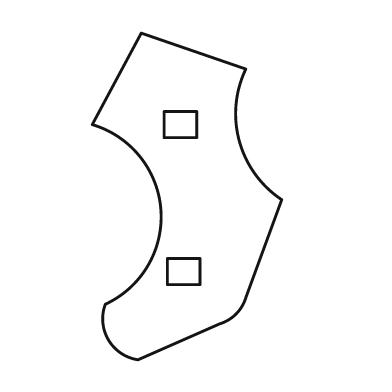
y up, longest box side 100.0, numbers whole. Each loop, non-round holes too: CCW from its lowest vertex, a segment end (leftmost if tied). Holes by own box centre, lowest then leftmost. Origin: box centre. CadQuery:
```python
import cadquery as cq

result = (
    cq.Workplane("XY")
    .moveTo(-15.0, -50.0)
    .lineTo(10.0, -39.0)
    .threePointArc((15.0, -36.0), (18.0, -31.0))
    .lineTo(29.0, -1.0)
    .threePointArc((16.0, 17.0), (18.0, 39.0))
    .lineTo(-14.0, 50.0)
    .lineTo(-29.0, 22.0)
    .threePointArc((-8.0, -4.0), (-25.0, -33.0))
    .threePointArc((-24.0, -44.0), (-15.0, -50.0))
    .close()
    .moveTo(-6.0, -27.0)
    .lineTo(4.0, -27.0)
    .lineTo(4.0, -19.0)
    .lineTo(-6.0, -19.0)
    .close()
    .moveTo(-7.0, 18.0)
    .lineTo(3.0, 18.0)
    .lineTo(3.0, 26.0)
    .lineTo(-7.0, 26.0)
    .close()
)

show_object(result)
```